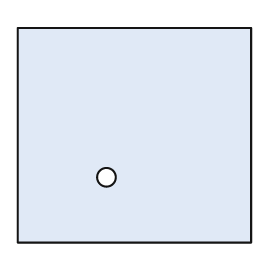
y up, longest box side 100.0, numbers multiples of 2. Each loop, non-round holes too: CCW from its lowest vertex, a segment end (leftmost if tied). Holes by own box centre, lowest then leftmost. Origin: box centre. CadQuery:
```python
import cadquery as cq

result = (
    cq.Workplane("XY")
    .moveTo(-50.0, -46.0)
    .lineTo(50.0, -46.0)
    .lineTo(50.0, 46.0)
    .lineTo(-50.0, 46.0)
    .close()
    .moveTo(-12.0, -18.0)
    .circle(4.0)
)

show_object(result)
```